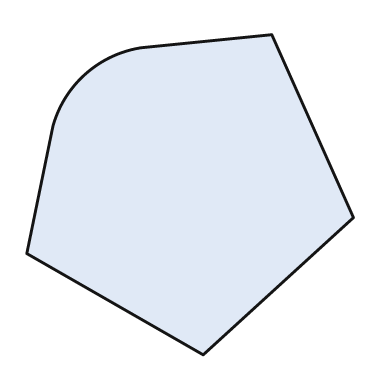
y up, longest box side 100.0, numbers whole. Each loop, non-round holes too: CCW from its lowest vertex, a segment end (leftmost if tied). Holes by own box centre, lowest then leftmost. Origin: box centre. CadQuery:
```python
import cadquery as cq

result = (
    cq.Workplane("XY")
    .moveTo(4.0, -49.0)
    .lineTo(50.0, -7.0)
    .lineTo(25.0, 49.0)
    .lineTo(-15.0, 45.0)
    .threePointArc((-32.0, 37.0), (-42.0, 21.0))
    .lineTo(-50.0, -18.0)
    .close()
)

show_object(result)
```